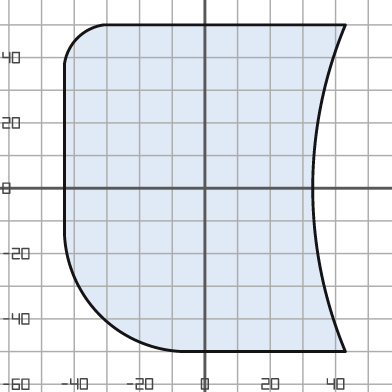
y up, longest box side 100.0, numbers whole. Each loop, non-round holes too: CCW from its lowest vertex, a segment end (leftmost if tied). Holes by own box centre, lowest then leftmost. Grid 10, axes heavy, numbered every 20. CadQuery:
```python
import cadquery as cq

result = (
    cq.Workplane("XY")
    .moveTo(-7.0, -50.0)
    .lineTo(43.0, -50.0)
    .threePointArc((33.0, 0.0), (43.0, 50.0))
    .lineTo(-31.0, 50.0)
    .threePointArc((-39.0, 46.0), (-43.0, 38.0))
    .lineTo(-43.0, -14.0)
    .threePointArc((-32.0, -39.0), (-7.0, -50.0))
    .close()
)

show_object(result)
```